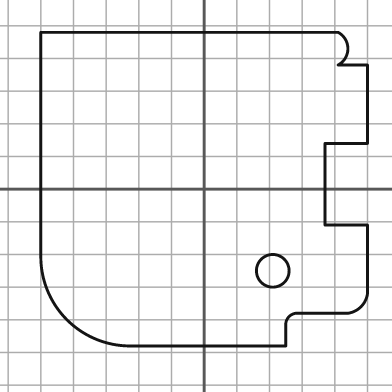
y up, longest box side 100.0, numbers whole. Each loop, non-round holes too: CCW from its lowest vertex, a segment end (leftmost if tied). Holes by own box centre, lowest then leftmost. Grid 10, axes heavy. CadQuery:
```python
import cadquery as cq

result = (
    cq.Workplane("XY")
    .moveTo(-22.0, -48.0)
    .lineTo(25.0, -48.0)
    .lineTo(25.0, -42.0)
    .threePointArc((26.0, -39.0), (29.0, -38.0))
    .lineTo(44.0, -38.0)
    .threePointArc((48.0, -36.0), (50.0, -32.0))
    .lineTo(50.0, -11.0)
    .lineTo(37.0, -11.0)
    .lineTo(37.0, 14.0)
    .lineTo(50.0, 14.0)
    .lineTo(50.0, 38.0)
    .lineTo(41.0, 38.0)
    .threePointArc((44.0, 43.0), (41.0, 48.0))
    .lineTo(-50.0, 48.0)
    .lineTo(-50.0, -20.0)
    .threePointArc((-42.0, -40.0), (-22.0, -48.0))
    .close()
    .moveTo(21.0, -25.0)
    .circle(5.0)
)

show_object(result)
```